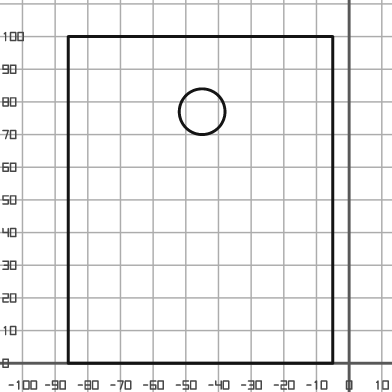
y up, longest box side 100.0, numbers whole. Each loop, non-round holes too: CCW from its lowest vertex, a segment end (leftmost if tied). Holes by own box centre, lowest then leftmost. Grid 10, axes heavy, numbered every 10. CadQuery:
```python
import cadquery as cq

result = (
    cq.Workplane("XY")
    .moveTo(-86.0, 0.0)
    .lineTo(-5.0, 0.0)
    .lineTo(-5.0, 100.0)
    .lineTo(-86.0, 100.0)
    .close()
    .moveTo(-45.0, 77.0)
    .circle(7.0)
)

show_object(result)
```